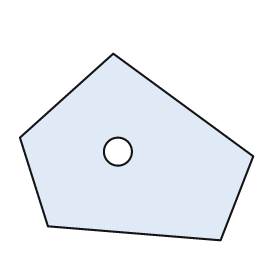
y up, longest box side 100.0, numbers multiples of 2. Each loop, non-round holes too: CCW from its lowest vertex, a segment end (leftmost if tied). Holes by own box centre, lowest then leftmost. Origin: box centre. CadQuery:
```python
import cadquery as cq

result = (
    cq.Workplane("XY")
    .moveTo(36.0, -40.0)
    .lineTo(50.0, -4.0)
    .lineTo(-10.0, 40.0)
    .lineTo(-50.0, 4.0)
    .lineTo(-38.0, -34.0)
    .close()
    .moveTo(-8.0, -2.0)
    .circle(6.0)
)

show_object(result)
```